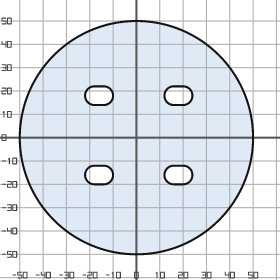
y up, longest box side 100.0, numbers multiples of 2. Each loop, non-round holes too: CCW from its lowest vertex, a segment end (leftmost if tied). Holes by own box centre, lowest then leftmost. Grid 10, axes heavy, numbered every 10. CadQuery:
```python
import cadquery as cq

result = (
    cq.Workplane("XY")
    .moveTo(0.0, 0.0)
    .circle(50.0)
    .moveTo(-18.0, -20.0)
    .lineTo(-14.0, -20.0)
    .threePointArc((-10.0, -16.0), (-14.0, -12.0))
    .lineTo(-18.0, -12.0)
    .threePointArc((-22.0, -16.0), (-18.0, -20.0))
    .close()
    .moveTo(16.0, -20.0)
    .lineTo(20.0, -20.0)
    .threePointArc((24.0, -16.0), (20.0, -12.0))
    .lineTo(16.0, -12.0)
    .threePointArc((12.0, -16.0), (16.0, -20.0))
    .close()
    .moveTo(-18.0, 14.0)
    .lineTo(-14.0, 14.0)
    .threePointArc((-10.0, 18.0), (-14.0, 22.0))
    .lineTo(-18.0, 22.0)
    .threePointArc((-22.0, 18.0), (-18.0, 14.0))
    .close()
    .moveTo(16.0, 14.0)
    .lineTo(20.0, 14.0)
    .threePointArc((24.0, 18.0), (20.0, 22.0))
    .lineTo(16.0, 22.0)
    .threePointArc((12.0, 18.0), (16.0, 14.0))
    .close()
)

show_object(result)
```